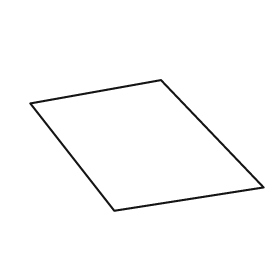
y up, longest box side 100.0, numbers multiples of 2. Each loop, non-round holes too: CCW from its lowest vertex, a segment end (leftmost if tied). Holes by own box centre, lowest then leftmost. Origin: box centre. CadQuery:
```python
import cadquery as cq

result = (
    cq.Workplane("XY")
    .moveTo(-14.0, -28.0)
    .lineTo(50.0, -18.0)
    .lineTo(6.0, 28.0)
    .lineTo(-50.0, 18.0)
    .close()
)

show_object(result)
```